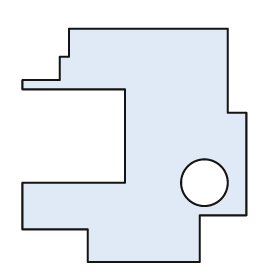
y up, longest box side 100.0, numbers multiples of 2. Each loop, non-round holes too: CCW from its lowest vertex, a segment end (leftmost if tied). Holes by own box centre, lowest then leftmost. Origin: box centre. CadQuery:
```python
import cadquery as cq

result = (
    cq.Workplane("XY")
    .moveTo(-20.0, -50.0)
    .lineTo(28.0, -50.0)
    .lineTo(28.0, -30.0)
    .lineTo(48.0, -30.0)
    .lineTo(48.0, 14.0)
    .lineTo(40.0, 14.0)
    .lineTo(40.0, 50.0)
    .lineTo(-28.0, 50.0)
    .lineTo(-28.0, 38.0)
    .lineTo(-32.0, 38.0)
    .lineTo(-32.0, 28.0)
    .lineTo(-48.0, 28.0)
    .lineTo(-48.0, 24.0)
    .lineTo(-4.0, 24.0)
    .lineTo(-4.0, -16.0)
    .lineTo(-48.0, -16.0)
    .lineTo(-48.0, -36.0)
    .lineTo(-20.0, -36.0)
    .close()
    .moveTo(30.0, -16.0)
    .circle(10.0)
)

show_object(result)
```